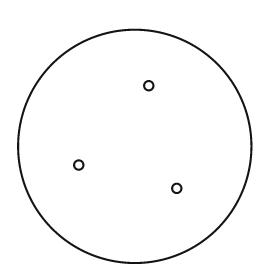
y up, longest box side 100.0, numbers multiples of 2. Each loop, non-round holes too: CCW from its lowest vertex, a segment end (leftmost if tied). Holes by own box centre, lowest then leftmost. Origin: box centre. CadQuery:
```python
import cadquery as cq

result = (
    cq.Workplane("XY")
    .moveTo(0.0, 0.0)
    .circle(50.0)
    .moveTo(18.0, -18.0)
    .circle(2.0)
    .moveTo(-24.0, -8.0)
    .circle(2.0)
    .moveTo(6.0, 26.0)
    .circle(2.0)
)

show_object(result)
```